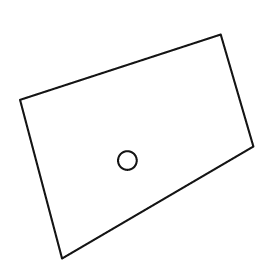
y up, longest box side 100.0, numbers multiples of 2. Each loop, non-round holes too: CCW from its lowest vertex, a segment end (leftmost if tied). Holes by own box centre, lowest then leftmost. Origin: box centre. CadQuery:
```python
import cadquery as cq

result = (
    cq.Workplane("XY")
    .moveTo(-32.0, -48.0)
    .lineTo(50.0, 0.0)
    .lineTo(36.0, 48.0)
    .lineTo(-50.0, 20.0)
    .close()
    .moveTo(-4.0, -6.0)
    .circle(4.0)
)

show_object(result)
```